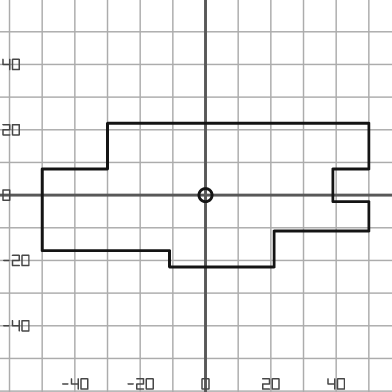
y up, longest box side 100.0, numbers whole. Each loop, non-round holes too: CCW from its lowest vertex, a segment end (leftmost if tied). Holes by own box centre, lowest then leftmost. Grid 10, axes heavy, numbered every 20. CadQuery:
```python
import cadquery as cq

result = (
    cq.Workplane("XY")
    .moveTo(-11.0, -22.0)
    .lineTo(21.0, -22.0)
    .lineTo(21.0, -11.0)
    .lineTo(50.0, -11.0)
    .lineTo(50.0, -2.0)
    .lineTo(39.0, -2.0)
    .lineTo(39.0, 8.0)
    .lineTo(50.0, 8.0)
    .lineTo(50.0, 22.0)
    .lineTo(-30.0, 22.0)
    .lineTo(-30.0, 8.0)
    .lineTo(-50.0, 8.0)
    .lineTo(-50.0, -17.0)
    .lineTo(-11.0, -17.0)
    .close()
    .moveTo(0.0, 0.0)
    .circle(2.0)
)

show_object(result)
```